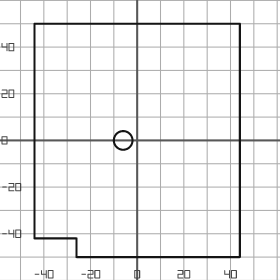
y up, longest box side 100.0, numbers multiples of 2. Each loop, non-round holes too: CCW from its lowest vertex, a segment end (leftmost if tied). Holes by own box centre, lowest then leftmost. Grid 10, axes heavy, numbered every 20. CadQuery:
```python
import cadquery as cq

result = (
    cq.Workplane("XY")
    .moveTo(-26.0, -50.0)
    .lineTo(44.0, -50.0)
    .lineTo(44.0, 50.0)
    .lineTo(-44.0, 50.0)
    .lineTo(-44.0, -42.0)
    .lineTo(-26.0, -42.0)
    .close()
    .moveTo(-6.0, 0.0)
    .circle(4.0)
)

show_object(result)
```